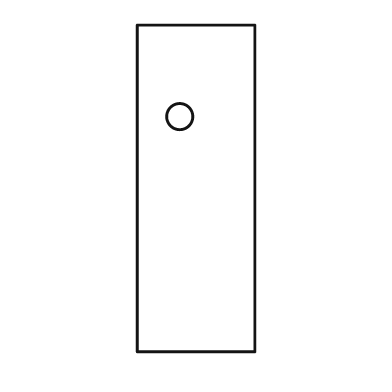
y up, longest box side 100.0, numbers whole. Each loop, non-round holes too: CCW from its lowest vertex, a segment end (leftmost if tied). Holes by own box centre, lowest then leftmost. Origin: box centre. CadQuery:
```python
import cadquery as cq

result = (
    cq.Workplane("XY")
    .moveTo(-18.0, -50.0)
    .lineTo(18.0, -50.0)
    .lineTo(18.0, 50.0)
    .lineTo(-18.0, 50.0)
    .close()
    .moveTo(-5.0, 22.0)
    .circle(4.0)
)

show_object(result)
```